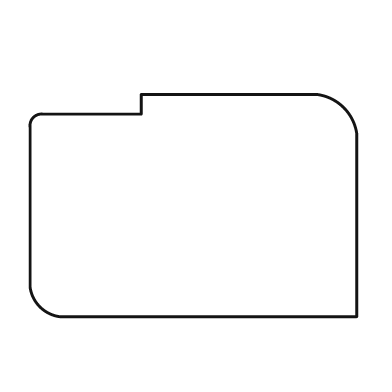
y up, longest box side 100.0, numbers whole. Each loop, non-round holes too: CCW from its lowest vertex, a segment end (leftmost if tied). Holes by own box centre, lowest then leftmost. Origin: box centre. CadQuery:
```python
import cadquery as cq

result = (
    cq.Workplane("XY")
    .moveTo(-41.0, -34.0)
    .lineTo(50.0, -34.0)
    .lineTo(50.0, 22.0)
    .threePointArc((46.0, 30.0), (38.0, 34.0))
    .lineTo(-16.0, 34.0)
    .lineTo(-16.0, 28.0)
    .lineTo(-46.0, 28.0)
    .threePointArc((-49.0, 27.0), (-50.0, 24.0))
    .lineTo(-50.0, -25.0)
    .threePointArc((-47.0, -31.0), (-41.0, -34.0))
    .close()
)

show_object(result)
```